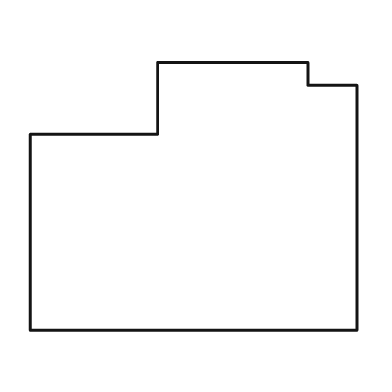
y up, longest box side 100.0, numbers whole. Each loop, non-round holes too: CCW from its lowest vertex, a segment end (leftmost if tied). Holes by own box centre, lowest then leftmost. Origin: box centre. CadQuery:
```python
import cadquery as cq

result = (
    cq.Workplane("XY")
    .moveTo(-50.0, -41.0)
    .lineTo(50.0, -41.0)
    .lineTo(50.0, 34.0)
    .lineTo(35.0, 34.0)
    .lineTo(35.0, 41.0)
    .lineTo(-11.0, 41.0)
    .lineTo(-11.0, 19.0)
    .lineTo(-50.0, 19.0)
    .close()
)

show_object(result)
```